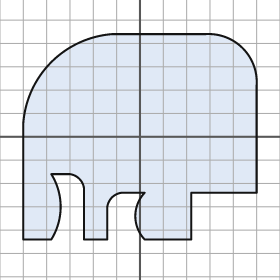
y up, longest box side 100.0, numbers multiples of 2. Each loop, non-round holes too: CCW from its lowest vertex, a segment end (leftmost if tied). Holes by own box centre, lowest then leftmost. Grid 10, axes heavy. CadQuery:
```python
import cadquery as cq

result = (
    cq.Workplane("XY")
    .moveTo(-50.0, -44.0)
    .lineTo(-38.0, -44.0)
    .threePointArc((-34.0, -30.0), (-38.0, -16.0))
    .lineTo(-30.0, -16.0)
    .threePointArc((-26.0, -18.0), (-24.0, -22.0))
    .lineTo(-24.0, -44.0)
    .lineTo(-14.0, -44.0)
    .lineTo(-14.0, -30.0)
    .threePointArc((-12.0, -26.0), (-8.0, -24.0))
    .lineTo(2.0, -24.0)
    .threePointArc((-2.0, -34.0), (2.0, -44.0))
    .lineTo(22.0, -44.0)
    .lineTo(22.0, -24.0)
    .lineTo(50.0, -24.0)
    .lineTo(50.0, 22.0)
    .threePointArc((44.0, 38.0), (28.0, 44.0))
    .lineTo(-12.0, 44.0)
    .threePointArc((-38.0, 32.0), (-50.0, 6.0))
    .close()
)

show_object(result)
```